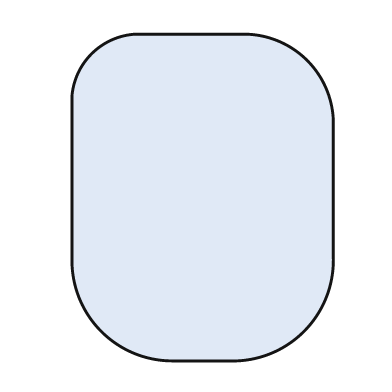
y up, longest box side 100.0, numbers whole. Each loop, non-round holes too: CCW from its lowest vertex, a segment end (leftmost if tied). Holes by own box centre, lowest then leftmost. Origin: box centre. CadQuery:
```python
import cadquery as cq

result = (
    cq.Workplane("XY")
    .moveTo(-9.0, -50.0)
    .lineTo(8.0, -50.0)
    .threePointArc((31.0, -41.0), (40.0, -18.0))
    .lineTo(40.0, 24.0)
    .threePointArc((32.0, 42.0), (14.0, 50.0))
    .lineTo(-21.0, 50.0)
    .threePointArc((-34.0, 44.0), (-40.0, 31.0))
    .lineTo(-40.0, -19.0)
    .threePointArc((-31.0, -41.0), (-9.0, -50.0))
    .close()
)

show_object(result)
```